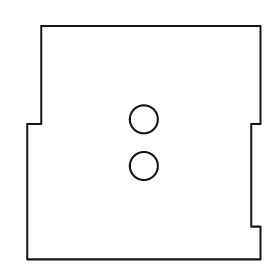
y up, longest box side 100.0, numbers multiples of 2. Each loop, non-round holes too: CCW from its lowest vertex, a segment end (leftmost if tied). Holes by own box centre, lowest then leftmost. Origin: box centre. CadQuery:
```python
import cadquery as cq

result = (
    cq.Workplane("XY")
    .moveTo(-50.0, -50.0)
    .lineTo(50.0, -50.0)
    .lineTo(50.0, -36.0)
    .lineTo(46.0, -36.0)
    .lineTo(46.0, 8.0)
    .lineTo(50.0, 8.0)
    .lineTo(50.0, 50.0)
    .lineTo(-44.0, 50.0)
    .lineTo(-44.0, 8.0)
    .lineTo(-50.0, 8.0)
    .close()
    .moveTo(0.0, -10.0)
    .circle(6.0)
    .moveTo(0.0, 10.0)
    .circle(6.0)
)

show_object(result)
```